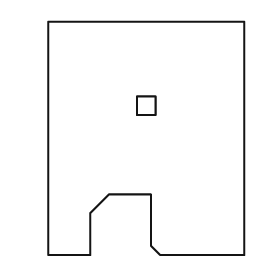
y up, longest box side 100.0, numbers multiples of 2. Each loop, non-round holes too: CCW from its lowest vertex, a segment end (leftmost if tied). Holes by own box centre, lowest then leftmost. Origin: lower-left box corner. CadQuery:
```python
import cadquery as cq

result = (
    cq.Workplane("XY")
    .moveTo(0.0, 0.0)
    .lineTo(18.0, 0.0)
    .lineTo(18.0, 18.0)
    .lineTo(26.0, 26.0)
    .lineTo(44.0, 26.0)
    .lineTo(44.0, 4.0)
    .lineTo(48.0, 0.0)
    .lineTo(84.0, 0.0)
    .lineTo(84.0, 100.0)
    .lineTo(0.0, 100.0)
    .close()
    .moveTo(38.0, 60.0)
    .lineTo(46.0, 60.0)
    .lineTo(46.0, 68.0)
    .lineTo(38.0, 68.0)
    .close()
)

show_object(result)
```